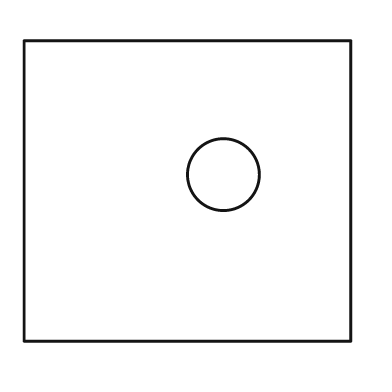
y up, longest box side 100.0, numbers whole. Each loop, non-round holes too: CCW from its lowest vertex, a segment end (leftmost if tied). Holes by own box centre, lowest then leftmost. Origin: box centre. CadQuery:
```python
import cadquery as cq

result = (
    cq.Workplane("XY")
    .moveTo(-50.0, -46.0)
    .lineTo(50.0, -46.0)
    .lineTo(50.0, 46.0)
    .lineTo(-50.0, 46.0)
    .close()
    .moveTo(11.0, 5.0)
    .circle(11.0)
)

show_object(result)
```